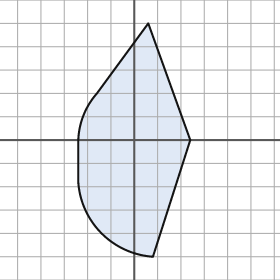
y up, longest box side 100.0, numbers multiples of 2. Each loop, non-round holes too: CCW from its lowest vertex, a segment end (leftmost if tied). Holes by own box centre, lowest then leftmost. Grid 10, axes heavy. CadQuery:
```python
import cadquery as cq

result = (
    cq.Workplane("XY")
    .moveTo(8.0, -50.0)
    .lineTo(24.0, 0.0)
    .lineTo(6.0, 50.0)
    .lineTo(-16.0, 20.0)
    .threePointArc((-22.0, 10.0), (-24.0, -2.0))
    .lineTo(-24.0, -18.0)
    .threePointArc((-14.0, -40.0), (8.0, -50.0))
    .close()
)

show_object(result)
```